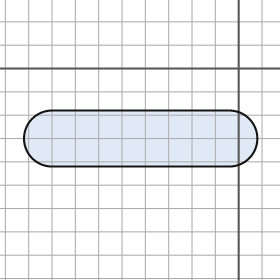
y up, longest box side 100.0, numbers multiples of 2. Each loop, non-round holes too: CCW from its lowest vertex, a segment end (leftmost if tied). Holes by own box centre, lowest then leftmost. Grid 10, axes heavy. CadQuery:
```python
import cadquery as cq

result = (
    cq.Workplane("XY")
    .moveTo(-80.0, -42.0)
    .lineTo(-4.0, -42.0)
    .threePointArc((8.0, -30.0), (-4.0, -18.0))
    .lineTo(-80.0, -18.0)
    .threePointArc((-92.0, -30.0), (-80.0, -42.0))
    .close()
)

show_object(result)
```